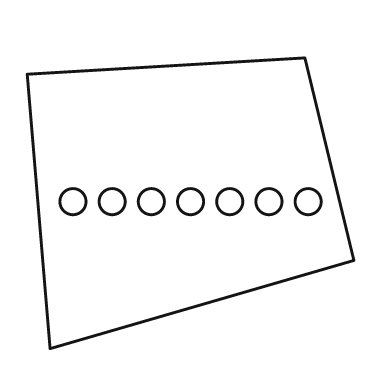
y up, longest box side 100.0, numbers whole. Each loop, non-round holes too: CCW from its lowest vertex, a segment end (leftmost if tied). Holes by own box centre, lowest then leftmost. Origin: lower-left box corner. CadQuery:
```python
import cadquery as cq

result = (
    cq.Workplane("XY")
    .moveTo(7.0, 0.0)
    .lineTo(100.0, 27.0)
    .lineTo(85.0, 89.0)
    .lineTo(0.0, 84.0)
    .close()
    .moveTo(14.0, 45.0)
    .circle(4.0)
    .moveTo(26.0, 45.0)
    .circle(4.0)
    .moveTo(38.0, 45.0)
    .circle(4.0)
    .moveTo(50.0, 45.0)
    .circle(4.0)
    .moveTo(62.0, 45.0)
    .circle(4.0)
    .moveTo(74.0, 45.0)
    .circle(4.0)
    .moveTo(86.0, 45.0)
    .circle(4.0)
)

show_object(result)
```